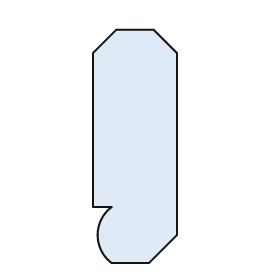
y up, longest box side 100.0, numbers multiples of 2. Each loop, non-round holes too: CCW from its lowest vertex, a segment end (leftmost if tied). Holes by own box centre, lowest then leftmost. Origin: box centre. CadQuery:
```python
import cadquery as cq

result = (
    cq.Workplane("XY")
    .moveTo(-10.0, -50.0)
    .lineTo(6.0, -50.0)
    .lineTo(18.0, -38.0)
    .lineTo(18.0, 40.0)
    .lineTo(8.0, 50.0)
    .lineTo(-8.0, 50.0)
    .lineTo(-18.0, 40.0)
    .lineTo(-18.0, -26.0)
    .lineTo(-10.0, -26.0)
    .threePointArc((-16.0, -38.0), (-10.0, -50.0))
    .close()
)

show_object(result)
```